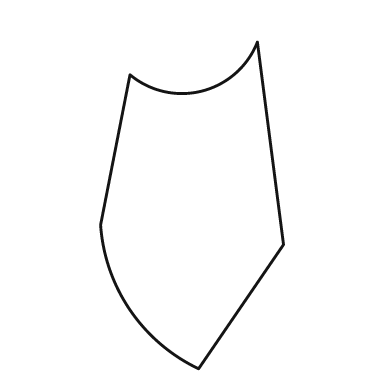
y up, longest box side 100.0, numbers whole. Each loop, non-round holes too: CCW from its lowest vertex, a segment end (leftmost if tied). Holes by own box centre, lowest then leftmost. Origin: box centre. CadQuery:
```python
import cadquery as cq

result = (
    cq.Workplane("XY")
    .moveTo(2.0, -50.0)
    .lineTo(28.0, -12.0)
    .lineTo(20.0, 50.0)
    .threePointArc((3.0, 35.0), (-19.0, 40.0))
    .lineTo(-28.0, -6.0)
    .threePointArc((-19.0, -32.0), (2.0, -50.0))
    .close()
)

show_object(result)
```